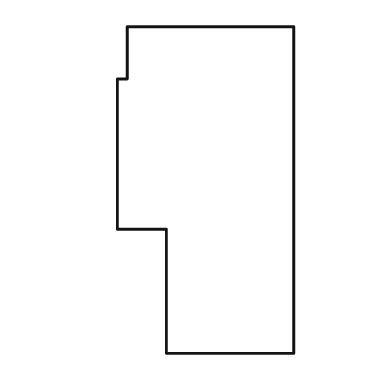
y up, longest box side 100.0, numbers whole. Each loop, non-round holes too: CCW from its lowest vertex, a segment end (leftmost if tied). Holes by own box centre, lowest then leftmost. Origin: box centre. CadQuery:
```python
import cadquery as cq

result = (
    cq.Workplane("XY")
    .moveTo(-12.0, -50.0)
    .lineTo(27.0, -50.0)
    .lineTo(27.0, 50.0)
    .lineTo(-24.0, 50.0)
    .lineTo(-24.0, 34.0)
    .lineTo(-27.0, 34.0)
    .lineTo(-27.0, -12.0)
    .lineTo(-12.0, -12.0)
    .close()
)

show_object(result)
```